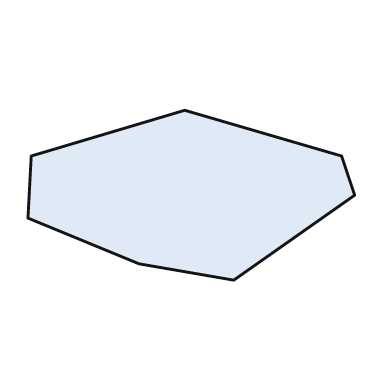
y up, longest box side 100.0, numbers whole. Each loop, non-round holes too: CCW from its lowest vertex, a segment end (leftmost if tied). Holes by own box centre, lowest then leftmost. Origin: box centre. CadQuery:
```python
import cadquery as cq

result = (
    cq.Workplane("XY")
    .moveTo(13.0, -26.0)
    .lineTo(50.0, 0.0)
    .lineTo(46.0, 12.0)
    .lineTo(-2.0, 26.0)
    .lineTo(-49.0, 12.0)
    .lineTo(-50.0, -7.0)
    .lineTo(-16.0, -21.0)
    .close()
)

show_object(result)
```